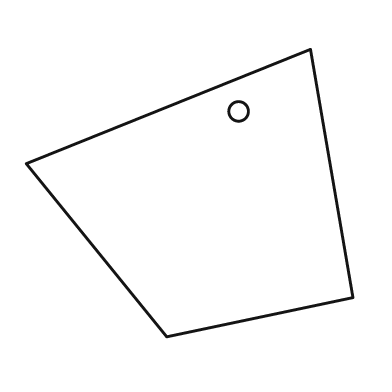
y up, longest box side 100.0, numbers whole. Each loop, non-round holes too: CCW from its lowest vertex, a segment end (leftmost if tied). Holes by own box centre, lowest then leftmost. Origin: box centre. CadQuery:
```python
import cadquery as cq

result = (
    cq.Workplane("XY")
    .moveTo(-7.0, -44.0)
    .lineTo(50.0, -32.0)
    .lineTo(37.0, 44.0)
    .lineTo(-50.0, 9.0)
    .close()
    .moveTo(15.0, 25.0)
    .circle(3.0)
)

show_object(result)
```